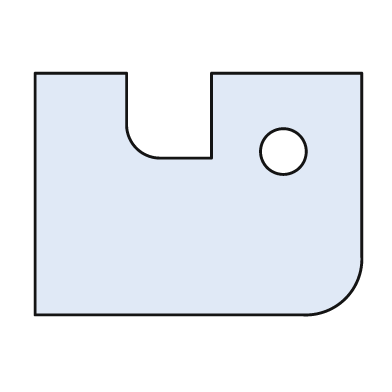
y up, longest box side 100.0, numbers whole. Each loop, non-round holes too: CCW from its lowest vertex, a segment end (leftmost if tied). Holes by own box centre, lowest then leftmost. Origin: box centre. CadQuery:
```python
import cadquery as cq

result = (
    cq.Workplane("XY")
    .moveTo(-50.0, -37.0)
    .lineTo(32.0, -37.0)
    .threePointArc((45.0, -32.0), (50.0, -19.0))
    .lineTo(50.0, 37.0)
    .lineTo(4.0, 37.0)
    .lineTo(4.0, 11.0)
    .lineTo(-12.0, 11.0)
    .threePointArc((-19.0, 14.0), (-22.0, 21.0))
    .lineTo(-22.0, 37.0)
    .lineTo(-50.0, 37.0)
    .close()
    .moveTo(26.0, 13.0)
    .circle(7.0)
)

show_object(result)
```